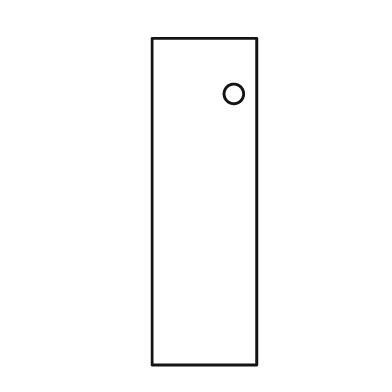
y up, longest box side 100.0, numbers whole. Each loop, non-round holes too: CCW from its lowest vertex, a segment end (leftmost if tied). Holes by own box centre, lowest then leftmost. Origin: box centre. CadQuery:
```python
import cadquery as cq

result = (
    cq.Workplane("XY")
    .moveTo(-16.0, -50.0)
    .lineTo(16.0, -50.0)
    .lineTo(16.0, 50.0)
    .lineTo(-16.0, 50.0)
    .close()
    .moveTo(9.0, 33.0)
    .circle(3.0)
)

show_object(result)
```